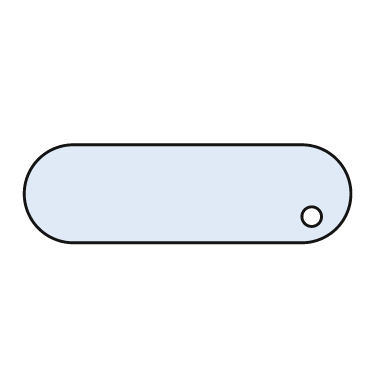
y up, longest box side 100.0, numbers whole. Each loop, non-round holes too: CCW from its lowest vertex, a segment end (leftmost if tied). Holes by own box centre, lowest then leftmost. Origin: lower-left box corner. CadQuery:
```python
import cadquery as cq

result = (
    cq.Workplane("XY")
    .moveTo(15.0, 0.0)
    .lineTo(85.0, 0.0)
    .threePointArc((100.0, 15.0), (85.0, 30.0))
    .lineTo(15.0, 30.0)
    .threePointArc((0.0, 15.0), (15.0, 0.0))
    .close()
    .moveTo(88.0, 8.0)
    .circle(3.0)
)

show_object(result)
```